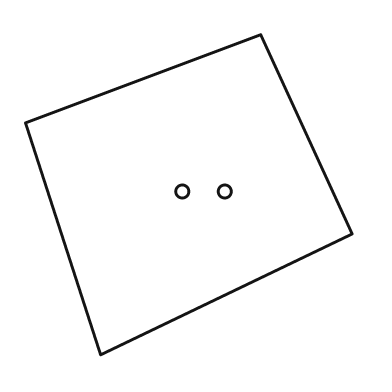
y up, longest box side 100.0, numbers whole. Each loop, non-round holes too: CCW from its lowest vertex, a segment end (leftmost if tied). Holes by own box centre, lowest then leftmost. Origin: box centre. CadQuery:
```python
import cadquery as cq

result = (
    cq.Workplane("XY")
    .moveTo(-27.0, -49.0)
    .lineTo(50.0, -12.0)
    .lineTo(22.0, 49.0)
    .lineTo(-50.0, 22.0)
    .close()
    .moveTo(-2.0, 1.0)
    .circle(2.0)
    .moveTo(11.0, 1.0)
    .circle(2.0)
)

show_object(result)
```